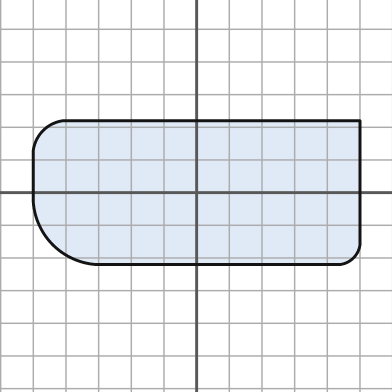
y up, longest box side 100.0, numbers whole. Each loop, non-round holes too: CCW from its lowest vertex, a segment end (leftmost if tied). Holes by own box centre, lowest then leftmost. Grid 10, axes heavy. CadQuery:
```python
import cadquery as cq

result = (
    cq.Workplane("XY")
    .moveTo(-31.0, -22.0)
    .lineTo(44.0, -22.0)
    .threePointArc((48.0, -20.0), (50.0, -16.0))
    .lineTo(50.0, 22.0)
    .lineTo(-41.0, 22.0)
    .threePointArc((-47.0, 19.0), (-50.0, 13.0))
    .lineTo(-50.0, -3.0)
    .threePointArc((-44.0, -16.0), (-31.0, -22.0))
    .close()
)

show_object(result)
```